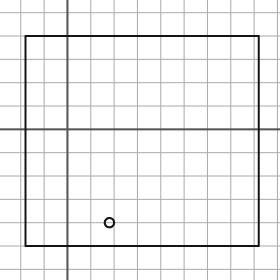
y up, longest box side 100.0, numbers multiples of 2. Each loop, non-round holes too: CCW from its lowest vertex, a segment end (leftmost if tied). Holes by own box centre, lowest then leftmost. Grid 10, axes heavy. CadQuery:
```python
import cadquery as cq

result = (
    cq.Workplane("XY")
    .moveTo(-18.0, -50.0)
    .lineTo(82.0, -50.0)
    .lineTo(82.0, 40.0)
    .lineTo(-18.0, 40.0)
    .close()
    .moveTo(18.0, -40.0)
    .circle(2.0)
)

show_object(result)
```